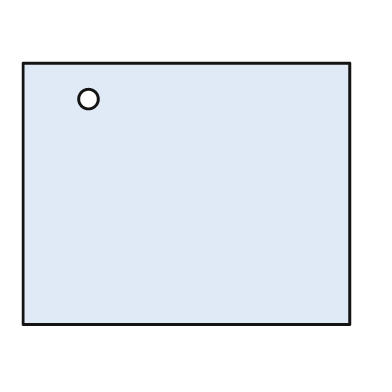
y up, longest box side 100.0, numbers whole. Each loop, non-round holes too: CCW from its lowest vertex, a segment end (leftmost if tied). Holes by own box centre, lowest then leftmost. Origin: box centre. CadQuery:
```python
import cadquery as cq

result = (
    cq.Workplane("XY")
    .moveTo(-50.0, -40.0)
    .lineTo(50.0, -40.0)
    .lineTo(50.0, 40.0)
    .lineTo(-50.0, 40.0)
    .close()
    .moveTo(-30.0, 29.0)
    .circle(3.0)
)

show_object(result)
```